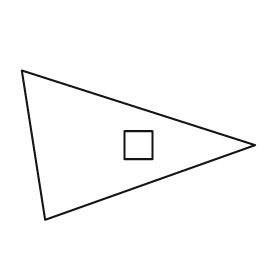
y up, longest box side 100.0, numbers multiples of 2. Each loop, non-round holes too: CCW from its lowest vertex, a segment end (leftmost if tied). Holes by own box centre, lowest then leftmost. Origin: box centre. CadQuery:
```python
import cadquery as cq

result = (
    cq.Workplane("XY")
    .moveTo(-40.0, -32.0)
    .lineTo(50.0, 0.0)
    .lineTo(-50.0, 32.0)
    .close()
    .moveTo(-6.0, -6.0)
    .lineTo(6.0, -6.0)
    .lineTo(6.0, 6.0)
    .lineTo(-6.0, 6.0)
    .close()
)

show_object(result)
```